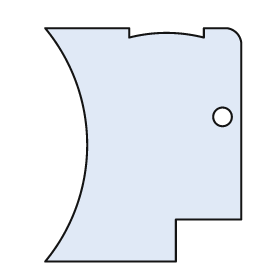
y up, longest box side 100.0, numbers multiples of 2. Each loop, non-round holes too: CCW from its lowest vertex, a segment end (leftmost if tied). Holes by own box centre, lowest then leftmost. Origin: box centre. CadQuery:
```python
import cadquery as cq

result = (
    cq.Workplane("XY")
    .moveTo(-42.0, -50.0)
    .lineTo(14.0, -50.0)
    .lineTo(14.0, -32.0)
    .lineTo(42.0, -32.0)
    .lineTo(42.0, 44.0)
    .threePointArc((40.0, 48.0), (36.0, 50.0))
    .lineTo(26.0, 50.0)
    .lineTo(26.0, 46.0)
    .threePointArc((10.0, 48.0), (-6.0, 46.0))
    .lineTo(-6.0, 50.0)
    .lineTo(-42.0, 50.0)
    .threePointArc((-24.0, 0.0), (-42.0, -50.0))
    .close()
    .moveTo(34.0, 12.0)
    .circle(4.0)
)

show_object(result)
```